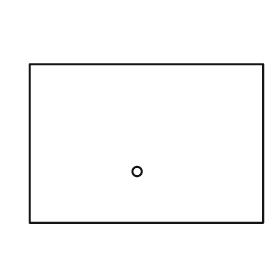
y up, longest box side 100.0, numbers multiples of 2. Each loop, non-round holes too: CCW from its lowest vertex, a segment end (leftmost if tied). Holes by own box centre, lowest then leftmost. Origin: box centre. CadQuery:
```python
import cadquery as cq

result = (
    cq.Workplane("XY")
    .moveTo(-50.0, -34.0)
    .lineTo(50.0, -34.0)
    .lineTo(50.0, 34.0)
    .lineTo(-50.0, 34.0)
    .close()
    .moveTo(-4.0, -12.0)
    .circle(2.0)
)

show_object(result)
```